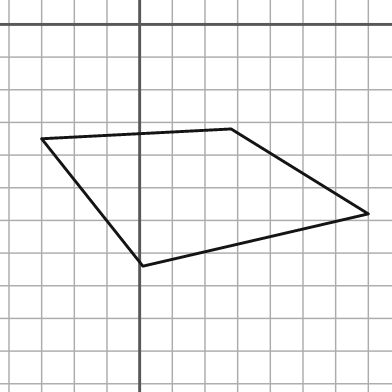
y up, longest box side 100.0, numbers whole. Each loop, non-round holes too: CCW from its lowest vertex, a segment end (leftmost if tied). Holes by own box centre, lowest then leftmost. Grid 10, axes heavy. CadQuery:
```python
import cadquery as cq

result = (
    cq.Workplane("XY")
    .moveTo(1.0, -74.0)
    .lineTo(70.0, -58.0)
    .lineTo(28.0, -32.0)
    .lineTo(-30.0, -35.0)
    .close()
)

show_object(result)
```